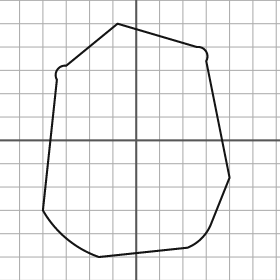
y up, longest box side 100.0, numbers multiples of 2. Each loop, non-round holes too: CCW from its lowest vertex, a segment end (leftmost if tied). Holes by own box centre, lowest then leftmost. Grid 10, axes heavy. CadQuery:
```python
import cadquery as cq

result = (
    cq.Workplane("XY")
    .moveTo(-16.0, -50.0)
    .lineTo(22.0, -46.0)
    .threePointArc((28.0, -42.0), (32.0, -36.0))
    .lineTo(40.0, -16.0)
    .lineTo(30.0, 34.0)
    .threePointArc((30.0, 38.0), (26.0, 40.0))
    .lineTo(-8.0, 50.0)
    .lineTo(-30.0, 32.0)
    .threePointArc((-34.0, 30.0), (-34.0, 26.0))
    .lineTo(-40.0, -30.0)
    .threePointArc((-30.0, -42.0), (-16.0, -50.0))
    .close()
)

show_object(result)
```